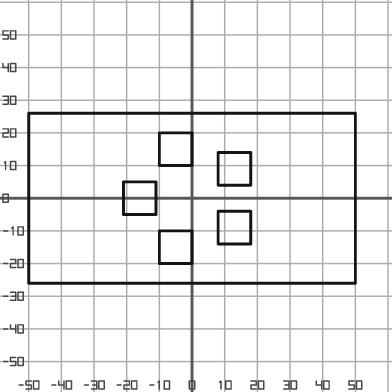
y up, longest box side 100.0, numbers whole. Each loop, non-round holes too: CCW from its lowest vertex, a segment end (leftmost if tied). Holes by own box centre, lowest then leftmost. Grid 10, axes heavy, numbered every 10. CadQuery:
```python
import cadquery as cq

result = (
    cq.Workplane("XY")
    .moveTo(-50.0, -26.0)
    .lineTo(50.0, -26.0)
    .lineTo(50.0, 26.0)
    .lineTo(-50.0, 26.0)
    .close()
    .moveTo(-10.0, -20.0)
    .lineTo(0.0, -20.0)
    .lineTo(0.0, -10.0)
    .lineTo(-10.0, -10.0)
    .close()
    .moveTo(8.0, -14.0)
    .lineTo(18.0, -14.0)
    .lineTo(18.0, -4.0)
    .lineTo(8.0, -4.0)
    .close()
    .moveTo(-21.0, -5.0)
    .lineTo(-11.0, -5.0)
    .lineTo(-11.0, 5.0)
    .lineTo(-21.0, 5.0)
    .close()
    .moveTo(8.0, 4.0)
    .lineTo(18.0, 4.0)
    .lineTo(18.0, 14.0)
    .lineTo(8.0, 14.0)
    .close()
    .moveTo(-10.0, 10.0)
    .lineTo(0.0, 10.0)
    .lineTo(0.0, 20.0)
    .lineTo(-10.0, 20.0)
    .close()
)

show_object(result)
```